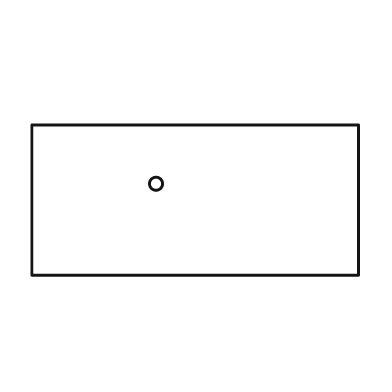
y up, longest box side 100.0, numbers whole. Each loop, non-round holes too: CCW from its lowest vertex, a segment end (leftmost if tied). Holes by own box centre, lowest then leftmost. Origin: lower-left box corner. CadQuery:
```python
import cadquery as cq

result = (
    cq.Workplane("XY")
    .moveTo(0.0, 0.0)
    .lineTo(100.0, 0.0)
    .lineTo(100.0, 46.0)
    .lineTo(0.0, 46.0)
    .close()
    .moveTo(38.0, 28.0)
    .circle(2.0)
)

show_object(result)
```